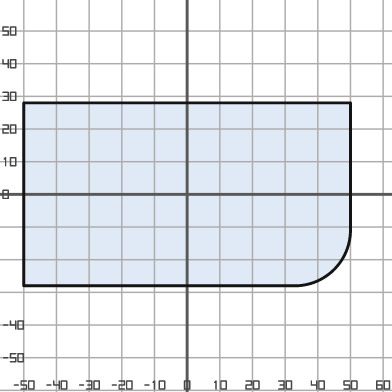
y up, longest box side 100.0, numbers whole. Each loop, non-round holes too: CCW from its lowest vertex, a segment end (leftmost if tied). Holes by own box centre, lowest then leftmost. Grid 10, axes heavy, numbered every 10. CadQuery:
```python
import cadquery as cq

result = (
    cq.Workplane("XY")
    .moveTo(-50.0, -28.0)
    .lineTo(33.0, -28.0)
    .threePointArc((45.0, -23.0), (50.0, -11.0))
    .lineTo(50.0, 28.0)
    .lineTo(-50.0, 28.0)
    .close()
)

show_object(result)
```